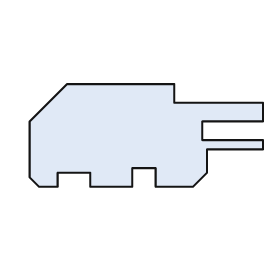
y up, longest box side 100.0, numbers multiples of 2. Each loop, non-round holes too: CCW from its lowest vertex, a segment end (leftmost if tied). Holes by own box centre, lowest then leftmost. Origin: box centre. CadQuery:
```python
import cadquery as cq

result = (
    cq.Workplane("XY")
    .moveTo(-46.0, -22.0)
    .lineTo(-38.0, -22.0)
    .lineTo(-38.0, -16.0)
    .lineTo(-24.0, -16.0)
    .lineTo(-24.0, -22.0)
    .lineTo(-6.0, -22.0)
    .lineTo(-6.0, -14.0)
    .lineTo(4.0, -14.0)
    .lineTo(4.0, -22.0)
    .lineTo(20.0, -22.0)
    .lineTo(26.0, -16.0)
    .lineTo(26.0, -6.0)
    .lineTo(50.0, -6.0)
    .lineTo(50.0, -2.0)
    .lineTo(24.0, -2.0)
    .lineTo(24.0, 6.0)
    .lineTo(50.0, 6.0)
    .lineTo(50.0, 14.0)
    .lineTo(12.0, 14.0)
    .lineTo(12.0, 22.0)
    .lineTo(-34.0, 22.0)
    .lineTo(-50.0, 6.0)
    .lineTo(-50.0, -18.0)
    .close()
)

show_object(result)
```